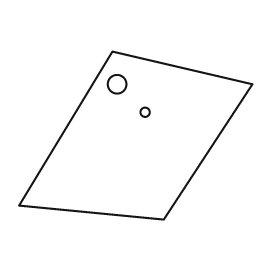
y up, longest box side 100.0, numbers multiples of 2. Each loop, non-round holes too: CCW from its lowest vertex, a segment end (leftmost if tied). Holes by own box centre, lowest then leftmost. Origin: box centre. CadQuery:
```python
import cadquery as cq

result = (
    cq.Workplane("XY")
    .moveTo(12.0, -36.0)
    .lineTo(50.0, 22.0)
    .lineTo(-10.0, 36.0)
    .lineTo(-50.0, -30.0)
    .close()
    .moveTo(4.0, 10.0)
    .circle(2.0)
    .moveTo(-8.0, 22.0)
    .circle(4.0)
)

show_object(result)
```